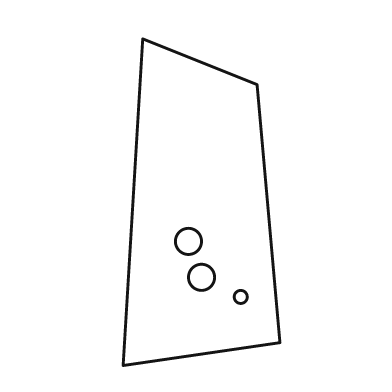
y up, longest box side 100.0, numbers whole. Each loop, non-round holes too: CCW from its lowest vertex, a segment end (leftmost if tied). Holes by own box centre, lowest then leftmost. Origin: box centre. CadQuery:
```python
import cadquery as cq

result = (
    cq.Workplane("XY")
    .moveTo(-24.0, -50.0)
    .lineTo(24.0, -43.0)
    .lineTo(17.0, 36.0)
    .lineTo(-18.0, 50.0)
    .close()
    .moveTo(12.0, -29.0)
    .circle(2.0)
    .moveTo(0.0, -23.0)
    .circle(4.0)
    .moveTo(-4.0, -12.0)
    .circle(4.0)
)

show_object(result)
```